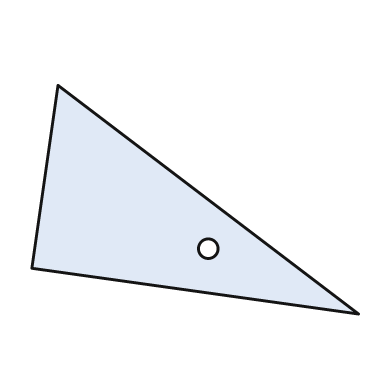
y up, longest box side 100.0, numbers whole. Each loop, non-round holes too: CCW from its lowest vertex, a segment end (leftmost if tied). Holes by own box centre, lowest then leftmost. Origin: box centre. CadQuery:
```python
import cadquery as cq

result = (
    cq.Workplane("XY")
    .moveTo(50.0, -35.0)
    .lineTo(-42.0, 35.0)
    .lineTo(-50.0, -21.0)
    .close()
    .moveTo(4.0, -15.0)
    .circle(3.0)
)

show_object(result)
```